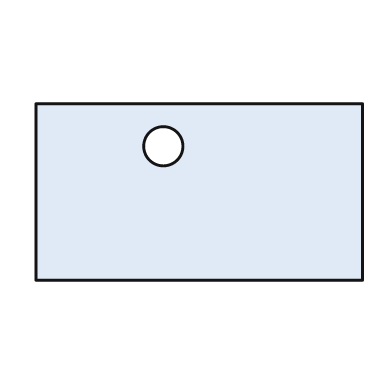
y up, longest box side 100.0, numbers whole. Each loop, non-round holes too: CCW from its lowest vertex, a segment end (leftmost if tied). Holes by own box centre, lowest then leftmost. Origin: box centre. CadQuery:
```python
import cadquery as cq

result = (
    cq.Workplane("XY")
    .moveTo(-50.0, -27.0)
    .lineTo(50.0, -27.0)
    .lineTo(50.0, 27.0)
    .lineTo(-50.0, 27.0)
    .close()
    .moveTo(-11.0, 14.0)
    .circle(6.0)
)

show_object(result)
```